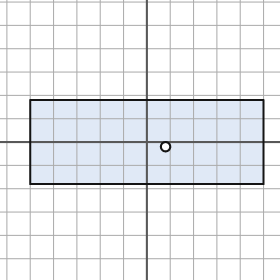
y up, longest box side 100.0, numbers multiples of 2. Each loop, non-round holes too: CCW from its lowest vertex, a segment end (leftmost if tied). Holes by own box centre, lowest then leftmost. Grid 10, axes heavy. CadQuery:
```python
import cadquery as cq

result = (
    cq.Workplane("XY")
    .moveTo(-50.0, -18.0)
    .lineTo(50.0, -18.0)
    .lineTo(50.0, 18.0)
    .lineTo(-50.0, 18.0)
    .close()
    .moveTo(8.0, -2.0)
    .circle(2.0)
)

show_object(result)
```